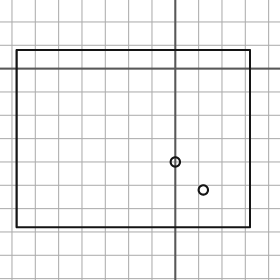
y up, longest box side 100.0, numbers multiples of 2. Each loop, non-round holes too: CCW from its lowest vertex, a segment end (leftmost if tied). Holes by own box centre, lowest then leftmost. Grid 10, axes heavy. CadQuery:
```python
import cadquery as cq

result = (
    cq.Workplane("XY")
    .moveTo(-68.0, -68.0)
    .lineTo(32.0, -68.0)
    .lineTo(32.0, 8.0)
    .lineTo(-68.0, 8.0)
    .close()
    .moveTo(12.0, -52.0)
    .circle(2.0)
    .moveTo(0.0, -40.0)
    .circle(2.0)
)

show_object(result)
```